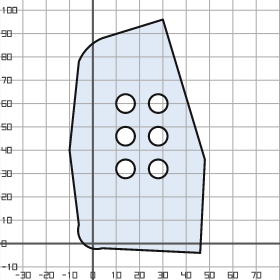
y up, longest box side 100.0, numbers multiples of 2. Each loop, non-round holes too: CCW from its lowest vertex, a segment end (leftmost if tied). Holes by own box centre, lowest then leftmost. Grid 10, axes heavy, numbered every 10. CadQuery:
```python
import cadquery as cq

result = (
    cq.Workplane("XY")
    .moveTo(46.0, -4.0)
    .lineTo(48.0, 36.0)
    .lineTo(30.0, 96.0)
    .lineTo(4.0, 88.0)
    .threePointArc((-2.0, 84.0), (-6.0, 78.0))
    .lineTo(-10.0, 40.0)
    .lineTo(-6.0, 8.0)
    .threePointArc((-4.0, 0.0), (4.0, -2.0))
    .close()
    .moveTo(14.0, 32.0)
    .circle(4.0)
    .moveTo(28.0, 32.0)
    .circle(4.0)
    .moveTo(14.0, 46.0)
    .circle(4.0)
    .moveTo(28.0, 46.0)
    .circle(4.0)
    .moveTo(14.0, 60.0)
    .circle(4.0)
    .moveTo(28.0, 60.0)
    .circle(4.0)
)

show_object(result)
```